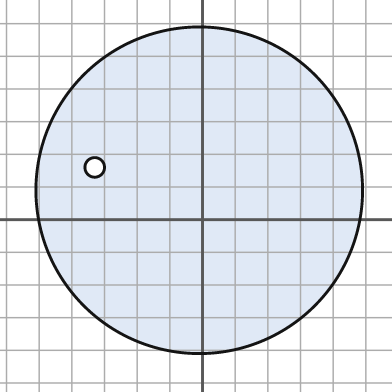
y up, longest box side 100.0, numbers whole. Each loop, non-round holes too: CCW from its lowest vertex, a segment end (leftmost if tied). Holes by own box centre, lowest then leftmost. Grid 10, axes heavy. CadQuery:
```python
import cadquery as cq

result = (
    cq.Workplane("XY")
    .moveTo(-1.0, 9.0)
    .circle(50.0)
    .moveTo(-33.0, 16.0)
    .circle(3.0)
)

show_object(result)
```